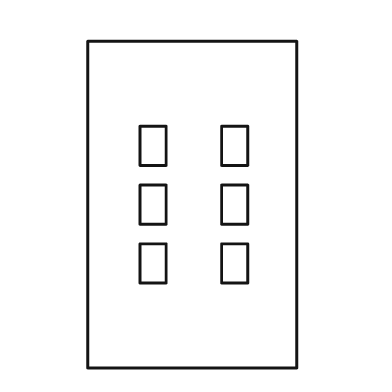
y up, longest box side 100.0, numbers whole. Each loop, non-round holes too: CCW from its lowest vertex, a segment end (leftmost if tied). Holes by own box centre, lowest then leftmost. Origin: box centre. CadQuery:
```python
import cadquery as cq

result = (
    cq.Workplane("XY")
    .moveTo(-32.0, -50.0)
    .lineTo(32.0, -50.0)
    .lineTo(32.0, 50.0)
    .lineTo(-32.0, 50.0)
    .close()
    .moveTo(-16.0, -24.0)
    .lineTo(-8.0, -24.0)
    .lineTo(-8.0, -12.0)
    .lineTo(-16.0, -12.0)
    .close()
    .moveTo(9.0, -24.0)
    .lineTo(17.0, -24.0)
    .lineTo(17.0, -12.0)
    .lineTo(9.0, -12.0)
    .close()
    .moveTo(-16.0, -6.0)
    .lineTo(-8.0, -6.0)
    .lineTo(-8.0, 6.0)
    .lineTo(-16.0, 6.0)
    .close()
    .moveTo(9.0, -6.0)
    .lineTo(17.0, -6.0)
    .lineTo(17.0, 6.0)
    .lineTo(9.0, 6.0)
    .close()
    .moveTo(-16.0, 12.0)
    .lineTo(-8.0, 12.0)
    .lineTo(-8.0, 24.0)
    .lineTo(-16.0, 24.0)
    .close()
    .moveTo(9.0, 12.0)
    .lineTo(17.0, 12.0)
    .lineTo(17.0, 24.0)
    .lineTo(9.0, 24.0)
    .close()
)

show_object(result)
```